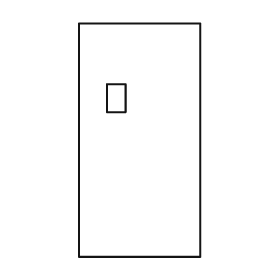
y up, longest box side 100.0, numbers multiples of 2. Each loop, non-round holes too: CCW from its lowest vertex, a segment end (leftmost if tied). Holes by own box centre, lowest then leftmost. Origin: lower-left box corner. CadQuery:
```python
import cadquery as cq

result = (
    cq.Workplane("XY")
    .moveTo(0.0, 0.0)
    .lineTo(52.0, 0.0)
    .lineTo(52.0, 100.0)
    .lineTo(0.0, 100.0)
    .close()
    .moveTo(12.0, 62.0)
    .lineTo(20.0, 62.0)
    .lineTo(20.0, 74.0)
    .lineTo(12.0, 74.0)
    .close()
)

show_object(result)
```